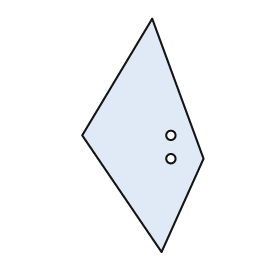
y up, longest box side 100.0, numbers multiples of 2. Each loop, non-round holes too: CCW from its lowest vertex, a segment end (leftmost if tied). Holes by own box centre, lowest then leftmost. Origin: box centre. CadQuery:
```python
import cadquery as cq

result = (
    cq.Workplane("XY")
    .moveTo(8.0, -50.0)
    .lineTo(26.0, -10.0)
    .lineTo(4.0, 50.0)
    .lineTo(-26.0, 0.0)
    .close()
    .moveTo(12.0, -10.0)
    .circle(2.0)
    .moveTo(12.0, 0.0)
    .circle(2.0)
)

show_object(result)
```